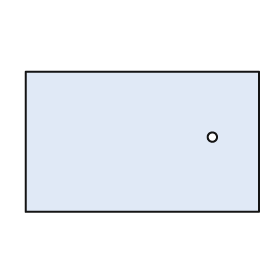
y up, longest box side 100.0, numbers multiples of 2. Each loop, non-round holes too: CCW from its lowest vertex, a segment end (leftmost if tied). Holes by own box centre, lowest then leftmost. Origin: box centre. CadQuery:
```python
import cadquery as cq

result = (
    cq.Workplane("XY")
    .moveTo(-50.0, -30.0)
    .lineTo(50.0, -30.0)
    .lineTo(50.0, 30.0)
    .lineTo(-50.0, 30.0)
    .close()
    .moveTo(30.0, 2.0)
    .circle(2.0)
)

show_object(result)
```